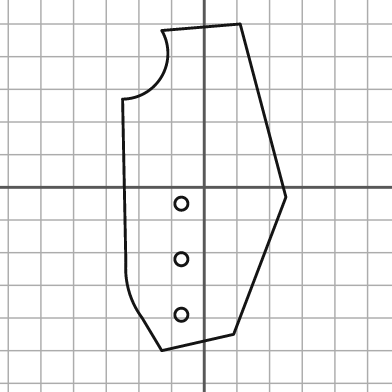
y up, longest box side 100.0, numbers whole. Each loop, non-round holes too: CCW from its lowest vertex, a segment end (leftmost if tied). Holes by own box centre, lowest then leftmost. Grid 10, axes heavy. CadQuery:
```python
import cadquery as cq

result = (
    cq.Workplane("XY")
    .moveTo(-13.0, -50.0)
    .lineTo(9.0, -45.0)
    .lineTo(25.0, -3.0)
    .lineTo(11.0, 50.0)
    .lineTo(-13.0, 48.0)
    .threePointArc((-13.0, 34.0), (-25.0, 27.0))
    .lineTo(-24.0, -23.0)
    .threePointArc((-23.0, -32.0), (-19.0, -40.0))
    .close()
    .moveTo(-7.0, -39.0)
    .circle(2.0)
    .moveTo(-7.0, -22.0)
    .circle(2.0)
    .moveTo(-7.0, -5.0)
    .circle(2.0)
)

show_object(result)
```